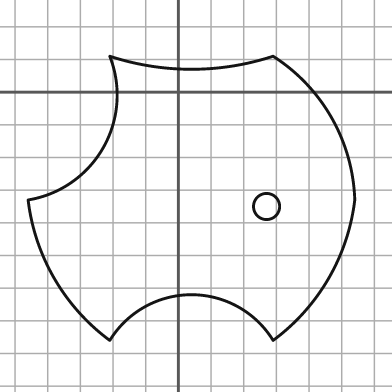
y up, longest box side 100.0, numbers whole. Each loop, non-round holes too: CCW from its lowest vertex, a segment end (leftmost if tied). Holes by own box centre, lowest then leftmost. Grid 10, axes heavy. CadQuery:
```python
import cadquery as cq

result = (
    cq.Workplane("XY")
    .moveTo(-21.0, -76.0)
    .threePointArc((4.0, -62.0), (29.0, -76.0))
    .threePointArc((46.0, -57.0), (54.0, -33.0))
    .threePointArc((47.0, -8.0), (29.0, 11.0))
    .threePointArc((4.0, 7.0), (-21.0, 11.0))
    .threePointArc((-23.0, -17.0), (-46.0, -33.0))
    .threePointArc((-38.0, -57.0), (-21.0, -76.0))
    .close()
    .moveTo(27.0, -35.0)
    .circle(4.0)
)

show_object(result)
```